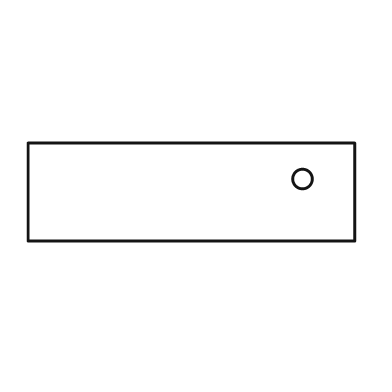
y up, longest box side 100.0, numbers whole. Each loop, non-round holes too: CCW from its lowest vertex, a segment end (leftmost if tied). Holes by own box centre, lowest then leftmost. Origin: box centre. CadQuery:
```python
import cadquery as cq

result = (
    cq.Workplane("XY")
    .moveTo(-50.0, -15.0)
    .lineTo(50.0, -15.0)
    .lineTo(50.0, 15.0)
    .lineTo(-50.0, 15.0)
    .close()
    .moveTo(34.0, 4.0)
    .circle(3.0)
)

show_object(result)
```